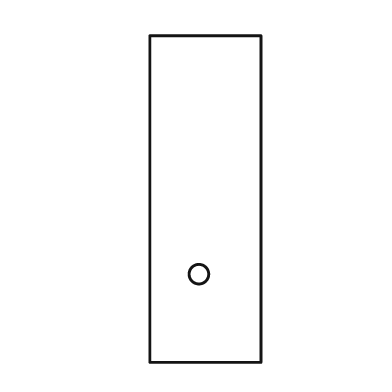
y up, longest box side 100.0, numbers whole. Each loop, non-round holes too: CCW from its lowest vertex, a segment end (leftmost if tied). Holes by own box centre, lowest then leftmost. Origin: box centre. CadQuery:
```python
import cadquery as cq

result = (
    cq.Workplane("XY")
    .moveTo(-17.0, -50.0)
    .lineTo(17.0, -50.0)
    .lineTo(17.0, 50.0)
    .lineTo(-17.0, 50.0)
    .close()
    .moveTo(-2.0, -23.0)
    .circle(3.0)
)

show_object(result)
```